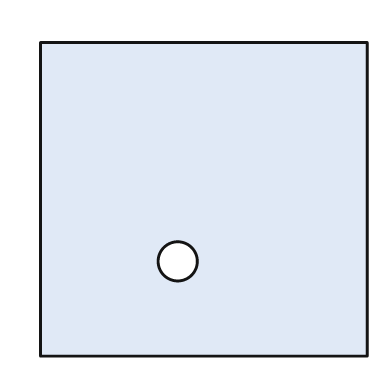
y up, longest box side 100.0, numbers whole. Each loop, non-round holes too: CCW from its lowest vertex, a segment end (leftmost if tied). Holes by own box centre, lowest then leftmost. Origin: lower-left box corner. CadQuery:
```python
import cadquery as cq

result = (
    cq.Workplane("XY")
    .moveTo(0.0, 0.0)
    .lineTo(100.0, 0.0)
    .lineTo(100.0, 96.0)
    .lineTo(0.0, 96.0)
    .close()
    .moveTo(42.0, 29.0)
    .circle(6.0)
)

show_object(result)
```